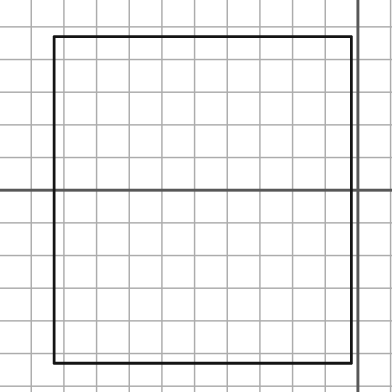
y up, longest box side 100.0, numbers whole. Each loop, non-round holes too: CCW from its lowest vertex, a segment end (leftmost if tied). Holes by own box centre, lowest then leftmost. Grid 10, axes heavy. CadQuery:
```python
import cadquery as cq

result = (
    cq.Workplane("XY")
    .moveTo(-93.0, -53.0)
    .lineTo(-2.0, -53.0)
    .lineTo(-2.0, 47.0)
    .lineTo(-93.0, 47.0)
    .close()
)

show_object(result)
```